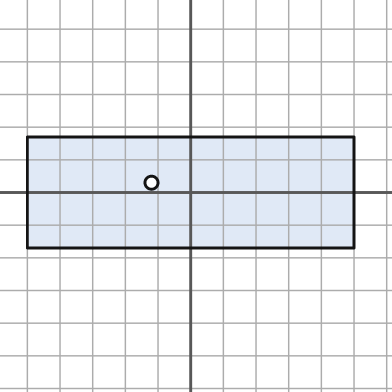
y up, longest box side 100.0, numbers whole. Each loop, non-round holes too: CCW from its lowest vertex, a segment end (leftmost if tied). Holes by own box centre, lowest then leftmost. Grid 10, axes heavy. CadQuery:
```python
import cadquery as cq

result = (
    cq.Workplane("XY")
    .moveTo(-50.0, -17.0)
    .lineTo(50.0, -17.0)
    .lineTo(50.0, 17.0)
    .lineTo(-50.0, 17.0)
    .close()
    .moveTo(-12.0, 3.0)
    .circle(2.0)
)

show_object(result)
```